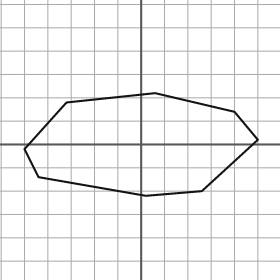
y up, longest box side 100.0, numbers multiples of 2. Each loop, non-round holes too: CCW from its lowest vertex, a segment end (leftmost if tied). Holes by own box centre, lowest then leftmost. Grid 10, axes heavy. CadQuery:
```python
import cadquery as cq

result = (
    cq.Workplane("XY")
    .moveTo(2.0, -22.0)
    .lineTo(26.0, -20.0)
    .lineTo(50.0, 2.0)
    .lineTo(40.0, 14.0)
    .lineTo(6.0, 22.0)
    .lineTo(-32.0, 18.0)
    .lineTo(-50.0, -2.0)
    .lineTo(-44.0, -14.0)
    .close()
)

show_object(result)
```